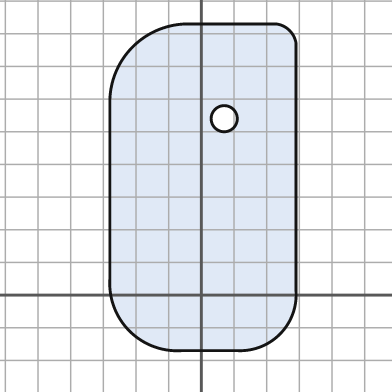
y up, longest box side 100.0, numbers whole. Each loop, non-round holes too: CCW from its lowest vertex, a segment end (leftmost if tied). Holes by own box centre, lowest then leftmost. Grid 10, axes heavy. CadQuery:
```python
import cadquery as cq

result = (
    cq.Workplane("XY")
    .moveTo(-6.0, -17.0)
    .lineTo(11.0, -17.0)
    .threePointArc((24.0, -12.0), (29.0, 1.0))
    .lineTo(29.0, 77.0)
    .threePointArc((27.0, 81.0), (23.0, 83.0))
    .lineTo(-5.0, 83.0)
    .threePointArc((-21.0, 76.0), (-28.0, 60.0))
    .lineTo(-28.0, 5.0)
    .threePointArc((-22.0, -11.0), (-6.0, -17.0))
    .close()
    .moveTo(7.0, 54.0)
    .circle(4.0)
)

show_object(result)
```